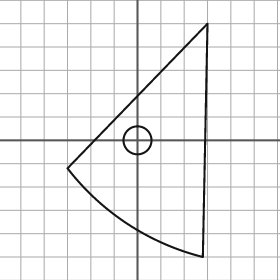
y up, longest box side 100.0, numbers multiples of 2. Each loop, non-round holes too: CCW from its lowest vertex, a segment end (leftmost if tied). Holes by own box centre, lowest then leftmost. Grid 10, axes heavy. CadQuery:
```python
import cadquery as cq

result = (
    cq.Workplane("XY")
    .moveTo(28.0, -50.0)
    .lineTo(30.0, 50.0)
    .lineTo(-30.0, -12.0)
    .threePointArc((-4.0, -36.0), (28.0, -50.0))
    .close()
    .moveTo(0.0, 0.0)
    .circle(6.0)
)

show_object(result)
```